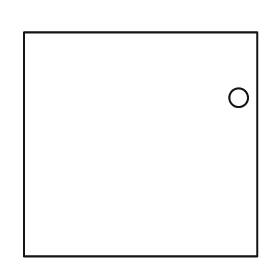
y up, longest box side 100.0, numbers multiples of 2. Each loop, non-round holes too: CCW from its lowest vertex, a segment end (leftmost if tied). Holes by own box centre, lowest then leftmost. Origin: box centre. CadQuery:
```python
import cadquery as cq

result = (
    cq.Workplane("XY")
    .moveTo(-50.0, -48.0)
    .lineTo(50.0, -48.0)
    .lineTo(50.0, 48.0)
    .lineTo(-50.0, 48.0)
    .close()
    .moveTo(42.0, 20.0)
    .circle(4.0)
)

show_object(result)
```